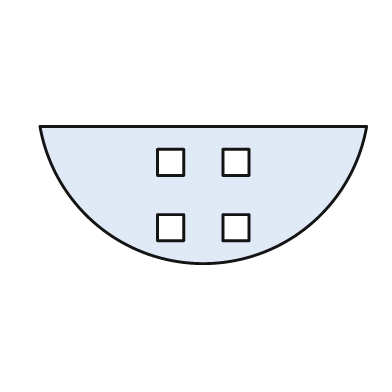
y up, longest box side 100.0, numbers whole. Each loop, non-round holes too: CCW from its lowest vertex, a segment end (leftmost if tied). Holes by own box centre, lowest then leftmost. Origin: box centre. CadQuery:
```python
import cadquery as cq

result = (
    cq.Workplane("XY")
    .moveTo(-50.0, 21.0)
    .threePointArc((0.0, -21.0), (50.0, 21.0))
    .close()
    .moveTo(-14.0, -14.0)
    .lineTo(-6.0, -14.0)
    .lineTo(-6.0, -6.0)
    .lineTo(-14.0, -6.0)
    .close()
    .moveTo(6.0, -14.0)
    .lineTo(14.0, -14.0)
    .lineTo(14.0, -6.0)
    .lineTo(6.0, -6.0)
    .close()
    .moveTo(-14.0, 6.0)
    .lineTo(-6.0, 6.0)
    .lineTo(-6.0, 14.0)
    .lineTo(-14.0, 14.0)
    .close()
    .moveTo(6.0, 6.0)
    .lineTo(14.0, 6.0)
    .lineTo(14.0, 14.0)
    .lineTo(6.0, 14.0)
    .close()
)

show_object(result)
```